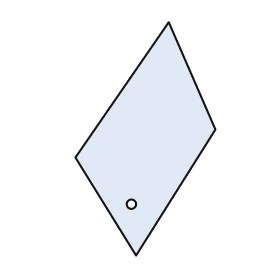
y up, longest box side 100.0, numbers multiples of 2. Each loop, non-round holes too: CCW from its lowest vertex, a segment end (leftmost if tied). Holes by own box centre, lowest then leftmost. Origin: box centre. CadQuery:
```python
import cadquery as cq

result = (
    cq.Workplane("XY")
    .moveTo(-4.0, -50.0)
    .lineTo(30.0, 4.0)
    .lineTo(10.0, 50.0)
    .lineTo(-30.0, -8.0)
    .close()
    .moveTo(-6.0, -28.0)
    .circle(2.0)
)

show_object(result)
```